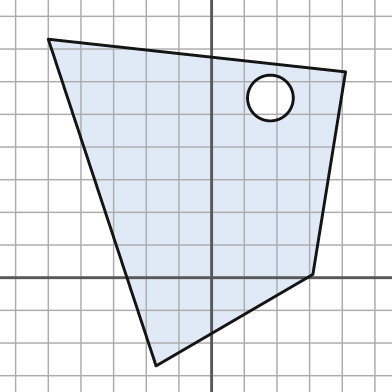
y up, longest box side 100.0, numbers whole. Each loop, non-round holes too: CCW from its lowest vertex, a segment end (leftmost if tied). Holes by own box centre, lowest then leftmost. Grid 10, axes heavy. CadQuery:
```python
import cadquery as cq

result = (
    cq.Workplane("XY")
    .moveTo(-17.0, -27.0)
    .lineTo(31.0, 1.0)
    .lineTo(41.0, 63.0)
    .lineTo(-50.0, 73.0)
    .close()
    .moveTo(18.0, 55.0)
    .circle(7.0)
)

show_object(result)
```